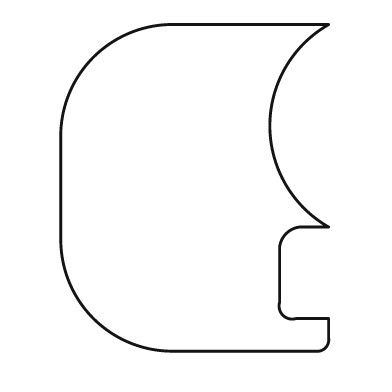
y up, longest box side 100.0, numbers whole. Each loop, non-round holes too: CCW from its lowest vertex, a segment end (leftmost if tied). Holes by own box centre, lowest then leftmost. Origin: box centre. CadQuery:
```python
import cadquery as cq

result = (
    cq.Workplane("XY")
    .moveTo(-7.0, -50.0)
    .lineTo(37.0, -50.0)
    .threePointArc((40.0, -49.0), (41.0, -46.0))
    .lineTo(41.0, -40.0)
    .lineTo(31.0, -40.0)
    .threePointArc((27.0, -39.0), (26.0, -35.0))
    .lineTo(26.0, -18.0)
    .threePointArc((28.0, -14.0), (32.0, -12.0))
    .lineTo(41.0, -12.0)
    .threePointArc((23.0, 19.0), (41.0, 50.0))
    .lineTo(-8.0, 50.0)
    .threePointArc((-31.0, 40.0), (-41.0, 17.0))
    .lineTo(-41.0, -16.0)
    .threePointArc((-31.0, -40.0), (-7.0, -50.0))
    .close()
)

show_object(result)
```